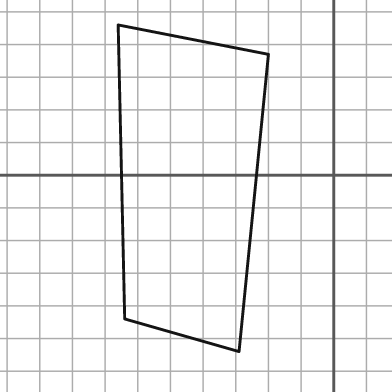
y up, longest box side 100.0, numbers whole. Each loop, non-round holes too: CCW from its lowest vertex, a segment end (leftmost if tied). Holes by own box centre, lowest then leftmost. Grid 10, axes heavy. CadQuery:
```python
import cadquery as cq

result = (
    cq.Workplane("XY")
    .moveTo(-29.0, -54.0)
    .lineTo(-20.0, 37.0)
    .lineTo(-66.0, 46.0)
    .lineTo(-64.0, -44.0)
    .close()
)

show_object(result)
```